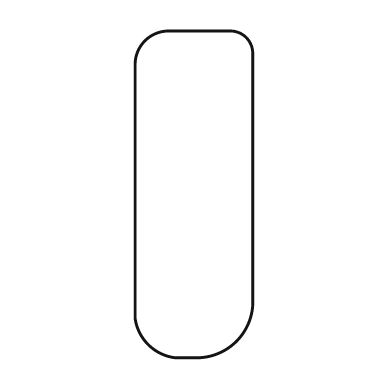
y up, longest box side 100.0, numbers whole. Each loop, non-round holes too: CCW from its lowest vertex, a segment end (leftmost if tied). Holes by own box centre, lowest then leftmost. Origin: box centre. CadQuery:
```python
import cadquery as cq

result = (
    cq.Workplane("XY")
    .moveTo(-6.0, -50.0)
    .lineTo(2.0, -50.0)
    .threePointArc((13.0, -45.0), (18.0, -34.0))
    .lineTo(18.0, 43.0)
    .threePointArc((16.0, 48.0), (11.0, 50.0))
    .lineTo(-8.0, 50.0)
    .threePointArc((-15.0, 47.0), (-18.0, 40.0))
    .lineTo(-18.0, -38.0)
    .threePointArc((-14.0, -46.0), (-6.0, -50.0))
    .close()
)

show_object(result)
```